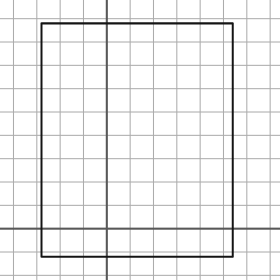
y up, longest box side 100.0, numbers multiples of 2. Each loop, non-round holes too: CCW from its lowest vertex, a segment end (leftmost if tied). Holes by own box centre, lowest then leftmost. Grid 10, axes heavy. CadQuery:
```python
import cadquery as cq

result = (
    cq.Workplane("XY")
    .moveTo(-28.0, -12.0)
    .lineTo(54.0, -12.0)
    .lineTo(54.0, 88.0)
    .lineTo(-28.0, 88.0)
    .close()
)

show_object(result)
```